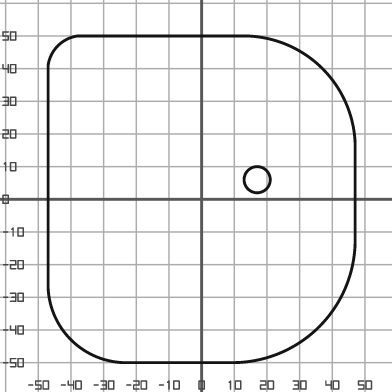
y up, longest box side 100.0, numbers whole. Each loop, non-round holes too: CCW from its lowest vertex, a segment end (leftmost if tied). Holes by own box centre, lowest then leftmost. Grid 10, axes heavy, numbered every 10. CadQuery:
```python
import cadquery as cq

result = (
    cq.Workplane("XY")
    .moveTo(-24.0, -50.0)
    .lineTo(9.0, -50.0)
    .threePointArc((36.0, -39.0), (47.0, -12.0))
    .lineTo(47.0, 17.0)
    .threePointArc((37.0, 40.0), (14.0, 50.0))
    .lineTo(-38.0, 50.0)
    .threePointArc((-44.0, 47.0), (-47.0, 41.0))
    .lineTo(-47.0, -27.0)
    .threePointArc((-40.0, -43.0), (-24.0, -50.0))
    .close()
    .moveTo(17.0, 6.0)
    .circle(4.0)
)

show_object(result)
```